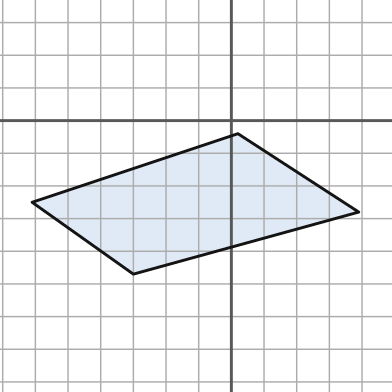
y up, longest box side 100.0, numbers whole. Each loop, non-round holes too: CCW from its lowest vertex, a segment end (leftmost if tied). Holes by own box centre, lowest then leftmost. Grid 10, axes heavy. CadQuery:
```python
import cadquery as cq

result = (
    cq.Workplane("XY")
    .moveTo(-30.0, -47.0)
    .lineTo(39.0, -28.0)
    .lineTo(2.0, -4.0)
    .lineTo(-61.0, -25.0)
    .close()
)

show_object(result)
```